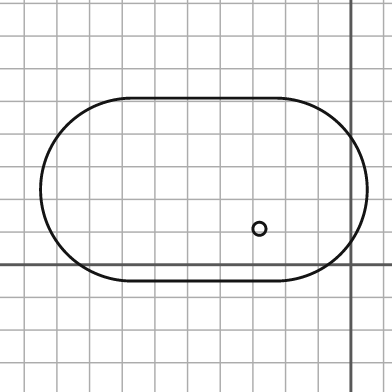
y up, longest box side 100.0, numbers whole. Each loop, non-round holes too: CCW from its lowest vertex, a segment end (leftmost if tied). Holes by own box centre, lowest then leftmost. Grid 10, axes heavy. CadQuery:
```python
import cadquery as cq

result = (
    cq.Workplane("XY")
    .moveTo(-67.0, -5.0)
    .lineTo(-23.0, -5.0)
    .threePointArc((5.0, 23.0), (-23.0, 51.0))
    .lineTo(-67.0, 51.0)
    .threePointArc((-95.0, 23.0), (-67.0, -5.0))
    .close()
    .moveTo(-28.0, 11.0)
    .circle(2.0)
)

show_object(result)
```